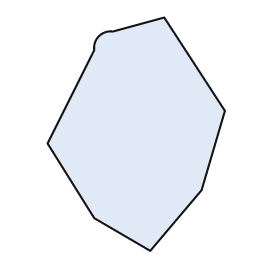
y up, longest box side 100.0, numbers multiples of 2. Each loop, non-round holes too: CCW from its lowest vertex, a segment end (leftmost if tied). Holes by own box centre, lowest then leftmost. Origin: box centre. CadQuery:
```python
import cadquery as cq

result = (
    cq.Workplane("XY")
    .moveTo(6.0, -50.0)
    .lineTo(28.0, -24.0)
    .lineTo(38.0, 10.0)
    .lineTo(12.0, 50.0)
    .lineTo(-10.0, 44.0)
    .threePointArc((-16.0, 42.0), (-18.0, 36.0))
    .lineTo(-38.0, -4.0)
    .lineTo(-18.0, -36.0)
    .close()
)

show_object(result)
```